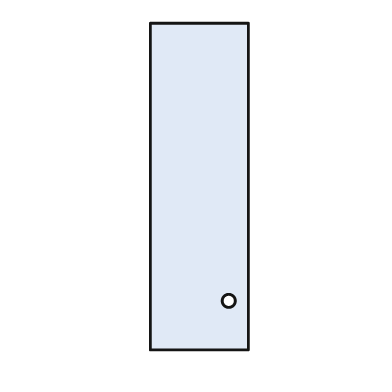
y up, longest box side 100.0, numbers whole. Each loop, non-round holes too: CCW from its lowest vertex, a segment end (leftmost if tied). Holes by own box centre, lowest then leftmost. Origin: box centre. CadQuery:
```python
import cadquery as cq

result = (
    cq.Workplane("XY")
    .moveTo(-15.0, -50.0)
    .lineTo(15.0, -50.0)
    .lineTo(15.0, 50.0)
    .lineTo(-15.0, 50.0)
    .close()
    .moveTo(9.0, -35.0)
    .circle(2.0)
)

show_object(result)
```